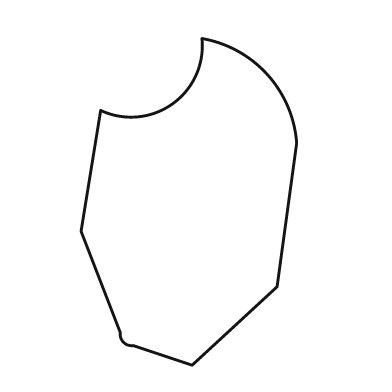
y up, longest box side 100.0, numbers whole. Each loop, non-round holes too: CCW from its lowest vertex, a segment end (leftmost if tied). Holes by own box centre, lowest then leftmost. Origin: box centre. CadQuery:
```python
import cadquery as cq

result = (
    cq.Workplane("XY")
    .moveTo(1.0, -50.0)
    .lineTo(27.0, -26.0)
    .lineTo(33.0, 18.0)
    .threePointArc((24.0, 39.0), (4.0, 50.0))
    .threePointArc((-5.0, 30.0), (-27.0, 28.0))
    .lineTo(-33.0, -9.0)
    .lineTo(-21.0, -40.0)
    .threePointArc((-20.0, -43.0), (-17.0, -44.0))
    .close()
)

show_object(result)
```